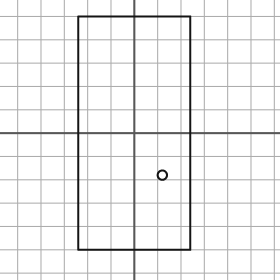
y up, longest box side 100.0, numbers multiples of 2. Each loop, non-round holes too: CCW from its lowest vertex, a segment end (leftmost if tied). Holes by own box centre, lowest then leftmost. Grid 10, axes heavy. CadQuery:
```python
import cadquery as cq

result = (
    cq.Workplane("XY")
    .moveTo(-24.0, -50.0)
    .lineTo(24.0, -50.0)
    .lineTo(24.0, 50.0)
    .lineTo(-24.0, 50.0)
    .close()
    .moveTo(12.0, -18.0)
    .circle(2.0)
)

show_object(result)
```